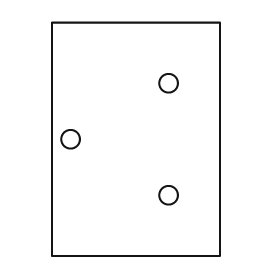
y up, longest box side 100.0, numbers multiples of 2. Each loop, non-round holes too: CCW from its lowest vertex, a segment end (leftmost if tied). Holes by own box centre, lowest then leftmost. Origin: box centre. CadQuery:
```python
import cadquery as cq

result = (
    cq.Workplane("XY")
    .moveTo(-36.0, -50.0)
    .lineTo(36.0, -50.0)
    .lineTo(36.0, 50.0)
    .lineTo(-36.0, 50.0)
    .close()
    .moveTo(14.0, -24.0)
    .circle(4.0)
    .moveTo(-28.0, 0.0)
    .circle(4.0)
    .moveTo(14.0, 24.0)
    .circle(4.0)
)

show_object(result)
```